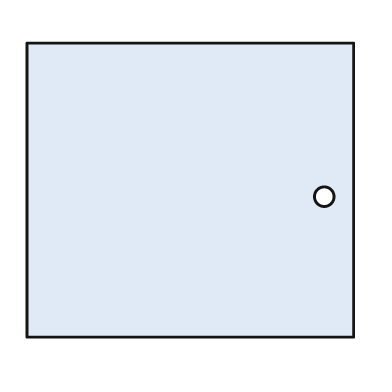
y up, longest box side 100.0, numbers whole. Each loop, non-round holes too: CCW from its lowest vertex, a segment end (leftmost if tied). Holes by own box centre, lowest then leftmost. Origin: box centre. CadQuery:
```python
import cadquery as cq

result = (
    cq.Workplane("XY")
    .moveTo(-50.0, -45.0)
    .lineTo(50.0, -45.0)
    .lineTo(50.0, 45.0)
    .lineTo(-50.0, 45.0)
    .close()
    .moveTo(41.0, -2.0)
    .circle(3.0)
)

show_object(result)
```